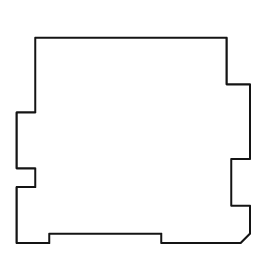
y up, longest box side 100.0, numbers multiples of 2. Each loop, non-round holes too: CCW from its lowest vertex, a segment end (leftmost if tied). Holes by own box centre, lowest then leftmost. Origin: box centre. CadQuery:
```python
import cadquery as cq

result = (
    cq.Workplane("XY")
    .moveTo(-50.0, -44.0)
    .lineTo(-36.0, -44.0)
    .lineTo(-36.0, -40.0)
    .lineTo(12.0, -40.0)
    .lineTo(12.0, -44.0)
    .lineTo(46.0, -44.0)
    .lineTo(50.0, -40.0)
    .lineTo(50.0, -28.0)
    .lineTo(42.0, -28.0)
    .lineTo(42.0, -8.0)
    .lineTo(50.0, -8.0)
    .lineTo(50.0, 24.0)
    .lineTo(40.0, 24.0)
    .lineTo(40.0, 44.0)
    .lineTo(-42.0, 44.0)
    .lineTo(-42.0, 12.0)
    .lineTo(-50.0, 12.0)
    .lineTo(-50.0, -12.0)
    .lineTo(-42.0, -12.0)
    .lineTo(-42.0, -20.0)
    .lineTo(-50.0, -20.0)
    .close()
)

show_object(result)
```